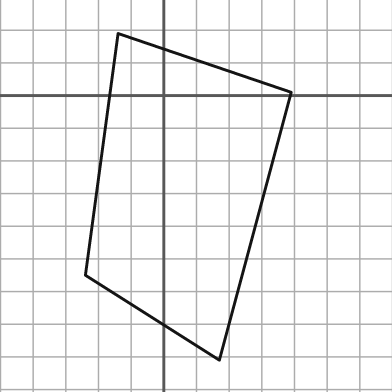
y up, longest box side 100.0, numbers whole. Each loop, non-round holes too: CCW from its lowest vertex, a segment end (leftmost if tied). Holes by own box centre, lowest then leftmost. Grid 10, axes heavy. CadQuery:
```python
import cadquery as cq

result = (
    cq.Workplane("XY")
    .moveTo(17.0, -81.0)
    .lineTo(39.0, 1.0)
    .lineTo(-14.0, 19.0)
    .lineTo(-24.0, -55.0)
    .close()
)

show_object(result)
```